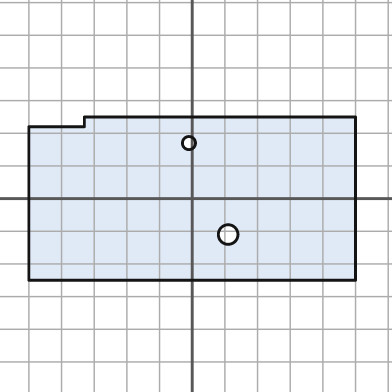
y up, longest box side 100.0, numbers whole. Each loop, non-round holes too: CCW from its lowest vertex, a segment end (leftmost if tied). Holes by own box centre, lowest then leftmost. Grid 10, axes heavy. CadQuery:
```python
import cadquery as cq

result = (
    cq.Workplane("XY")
    .moveTo(-50.0, -25.0)
    .lineTo(50.0, -25.0)
    .lineTo(50.0, 25.0)
    .lineTo(-33.0, 25.0)
    .lineTo(-33.0, 22.0)
    .lineTo(-50.0, 22.0)
    .close()
    .moveTo(11.0, -11.0)
    .circle(3.0)
    .moveTo(-1.0, 17.0)
    .circle(2.0)
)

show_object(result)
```